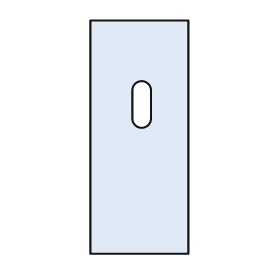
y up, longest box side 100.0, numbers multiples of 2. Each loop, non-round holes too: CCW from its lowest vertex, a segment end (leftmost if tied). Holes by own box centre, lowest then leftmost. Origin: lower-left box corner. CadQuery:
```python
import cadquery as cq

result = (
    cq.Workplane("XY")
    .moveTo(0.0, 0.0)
    .lineTo(42.0, 0.0)
    .lineTo(42.0, 100.0)
    .lineTo(0.0, 100.0)
    .close()
    .moveTo(18.0, 58.0)
    .threePointArc((22.0, 54.0), (26.0, 58.0))
    .lineTo(26.0, 70.0)
    .threePointArc((22.0, 74.0), (18.0, 70.0))
    .close()
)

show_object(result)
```